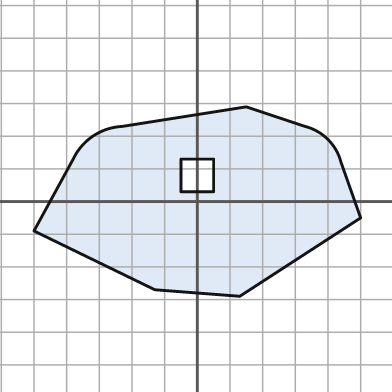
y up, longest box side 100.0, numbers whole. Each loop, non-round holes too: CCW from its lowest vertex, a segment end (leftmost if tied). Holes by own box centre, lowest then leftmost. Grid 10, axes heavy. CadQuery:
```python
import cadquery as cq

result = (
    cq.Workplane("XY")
    .moveTo(13.0, -29.0)
    .lineTo(50.0, -5.0)
    .lineTo(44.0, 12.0)
    .threePointArc((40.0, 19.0), (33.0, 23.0))
    .lineTo(15.0, 29.0)
    .lineTo(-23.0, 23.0)
    .threePointArc((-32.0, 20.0), (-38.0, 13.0))
    .lineTo(-50.0, -9.0)
    .lineTo(-13.0, -27.0)
    .close()
    .moveTo(-5.0, 3.0)
    .lineTo(5.0, 3.0)
    .lineTo(5.0, 13.0)
    .lineTo(-5.0, 13.0)
    .close()
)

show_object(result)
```